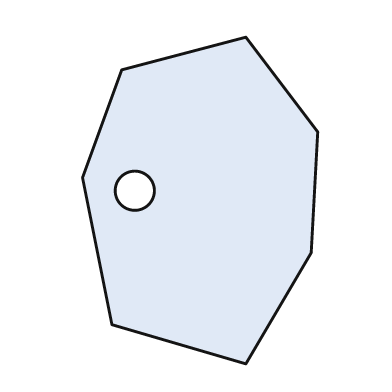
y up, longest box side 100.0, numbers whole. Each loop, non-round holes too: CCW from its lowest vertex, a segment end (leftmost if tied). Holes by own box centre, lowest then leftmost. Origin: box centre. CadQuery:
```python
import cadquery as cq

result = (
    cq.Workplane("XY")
    .moveTo(14.0, -50.0)
    .lineTo(34.0, -16.0)
    .lineTo(36.0, 21.0)
    .lineTo(14.0, 50.0)
    .lineTo(-24.0, 40.0)
    .lineTo(-36.0, 7.0)
    .lineTo(-27.0, -38.0)
    .close()
    .moveTo(-20.0, 3.0)
    .circle(6.0)
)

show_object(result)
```